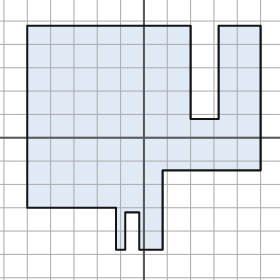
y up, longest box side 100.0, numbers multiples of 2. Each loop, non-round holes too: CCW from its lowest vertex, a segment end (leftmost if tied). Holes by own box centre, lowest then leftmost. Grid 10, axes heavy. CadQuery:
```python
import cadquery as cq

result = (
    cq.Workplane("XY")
    .moveTo(-12.0, -48.0)
    .lineTo(-8.0, -48.0)
    .lineTo(-8.0, -32.0)
    .lineTo(-2.0, -32.0)
    .lineTo(-2.0, -48.0)
    .lineTo(8.0, -48.0)
    .lineTo(8.0, -14.0)
    .lineTo(50.0, -14.0)
    .lineTo(50.0, 48.0)
    .lineTo(32.0, 48.0)
    .lineTo(32.0, 8.0)
    .lineTo(20.0, 8.0)
    .lineTo(20.0, 48.0)
    .lineTo(-50.0, 48.0)
    .lineTo(-50.0, -30.0)
    .lineTo(-12.0, -30.0)
    .close()
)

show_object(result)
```